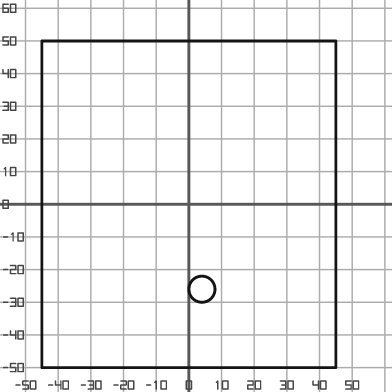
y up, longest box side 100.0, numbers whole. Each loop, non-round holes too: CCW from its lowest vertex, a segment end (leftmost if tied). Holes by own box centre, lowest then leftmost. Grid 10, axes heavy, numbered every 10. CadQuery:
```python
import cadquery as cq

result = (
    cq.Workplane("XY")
    .moveTo(-45.0, -50.0)
    .lineTo(45.0, -50.0)
    .lineTo(45.0, 50.0)
    .lineTo(-45.0, 50.0)
    .close()
    .moveTo(4.0, -26.0)
    .circle(4.0)
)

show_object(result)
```